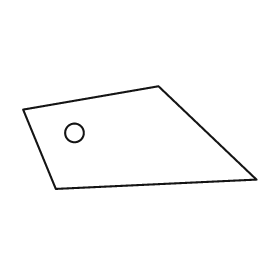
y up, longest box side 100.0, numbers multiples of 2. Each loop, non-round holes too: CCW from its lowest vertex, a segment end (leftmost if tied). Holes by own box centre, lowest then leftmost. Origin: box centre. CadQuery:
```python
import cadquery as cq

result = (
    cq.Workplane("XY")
    .moveTo(-36.0, -22.0)
    .lineTo(50.0, -18.0)
    .lineTo(8.0, 22.0)
    .lineTo(-50.0, 12.0)
    .close()
    .moveTo(-28.0, 2.0)
    .circle(4.0)
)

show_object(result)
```